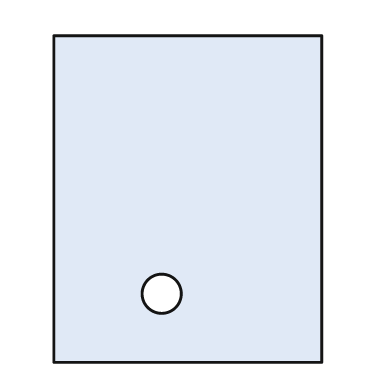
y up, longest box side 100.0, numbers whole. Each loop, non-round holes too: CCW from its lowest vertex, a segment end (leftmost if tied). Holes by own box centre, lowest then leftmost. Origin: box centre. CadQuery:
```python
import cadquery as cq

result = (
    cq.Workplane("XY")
    .moveTo(-41.0, -50.0)
    .lineTo(41.0, -50.0)
    .lineTo(41.0, 50.0)
    .lineTo(-41.0, 50.0)
    .close()
    .moveTo(-8.0, -29.0)
    .circle(6.0)
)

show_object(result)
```